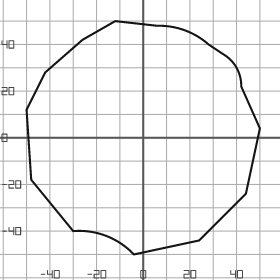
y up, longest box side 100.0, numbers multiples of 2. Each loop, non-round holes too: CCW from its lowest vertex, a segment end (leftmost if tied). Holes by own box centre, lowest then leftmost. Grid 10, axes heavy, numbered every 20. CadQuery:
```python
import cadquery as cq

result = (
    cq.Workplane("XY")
    .moveTo(-4.0, -50.0)
    .lineTo(24.0, -44.0)
    .lineTo(44.0, -24.0)
    .lineTo(50.0, 4.0)
    .lineTo(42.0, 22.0)
    .threePointArc((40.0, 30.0), (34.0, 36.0))
    .lineTo(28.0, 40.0)
    .threePointArc((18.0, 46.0), (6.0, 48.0))
    .lineTo(-12.0, 50.0)
    .lineTo(-26.0, 42.0)
    .lineTo(-42.0, 28.0)
    .lineTo(-50.0, 12.0)
    .lineTo(-48.0, -18.0)
    .lineTo(-30.0, -40.0)
    .threePointArc((-16.0, -42.0), (-4.0, -50.0))
    .close()
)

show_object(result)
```